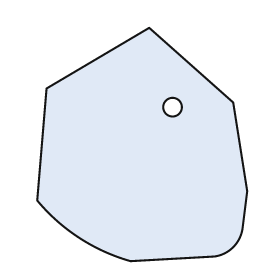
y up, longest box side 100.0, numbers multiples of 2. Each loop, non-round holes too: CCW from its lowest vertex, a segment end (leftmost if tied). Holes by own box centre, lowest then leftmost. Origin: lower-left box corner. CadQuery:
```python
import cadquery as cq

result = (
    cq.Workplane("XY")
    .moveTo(40.0, 0.0)
    .lineTo(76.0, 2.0)
    .threePointArc((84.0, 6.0), (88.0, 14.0))
    .lineTo(90.0, 30.0)
    .lineTo(84.0, 68.0)
    .lineTo(48.0, 100.0)
    .lineTo(4.0, 74.0)
    .lineTo(0.0, 26.0)
    .threePointArc((18.0, 10.0), (40.0, 0.0))
    .close()
    .moveTo(58.0, 66.0)
    .circle(4.0)
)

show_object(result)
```